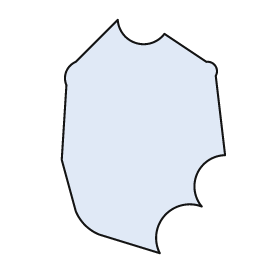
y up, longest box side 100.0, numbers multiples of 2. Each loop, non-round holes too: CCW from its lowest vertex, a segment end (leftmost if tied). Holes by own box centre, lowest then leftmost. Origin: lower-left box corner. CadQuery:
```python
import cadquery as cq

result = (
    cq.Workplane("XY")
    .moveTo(42.0, 0.0)
    .threePointArc((44.0, 16.0), (60.0, 20.0))
    .threePointArc((58.0, 34.0), (70.0, 42.0))
    .lineTo(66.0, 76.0)
    .threePointArc((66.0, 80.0), (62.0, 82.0))
    .lineTo(44.0, 94.0)
    .threePointArc((32.0, 90.0), (24.0, 100.0))
    .lineTo(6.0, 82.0)
    .threePointArc((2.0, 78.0), (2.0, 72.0))
    .lineTo(0.0, 40.0)
    .lineTo(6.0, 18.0)
    .threePointArc((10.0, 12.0), (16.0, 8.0))
    .close()
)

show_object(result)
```